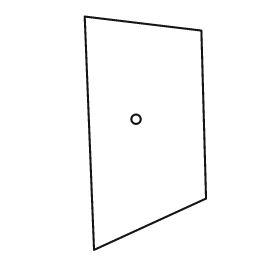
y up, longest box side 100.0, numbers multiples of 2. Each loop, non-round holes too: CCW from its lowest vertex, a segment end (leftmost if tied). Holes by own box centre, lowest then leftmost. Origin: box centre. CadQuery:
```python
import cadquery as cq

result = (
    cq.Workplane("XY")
    .moveTo(-22.0, -50.0)
    .lineTo(26.0, -28.0)
    .lineTo(24.0, 44.0)
    .lineTo(-26.0, 50.0)
    .close()
    .moveTo(-4.0, 6.0)
    .circle(2.0)
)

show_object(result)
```